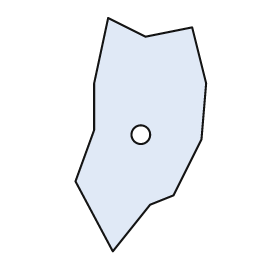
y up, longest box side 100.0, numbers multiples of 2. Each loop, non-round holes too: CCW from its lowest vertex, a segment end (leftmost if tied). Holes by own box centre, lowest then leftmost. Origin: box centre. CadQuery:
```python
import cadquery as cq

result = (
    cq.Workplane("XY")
    .moveTo(-12.0, -50.0)
    .lineTo(4.0, -30.0)
    .lineTo(14.0, -26.0)
    .lineTo(26.0, -2.0)
    .lineTo(28.0, 22.0)
    .lineTo(22.0, 46.0)
    .lineTo(2.0, 42.0)
    .lineTo(-14.0, 50.0)
    .lineTo(-20.0, 22.0)
    .lineTo(-20.0, 2.0)
    .lineTo(-28.0, -20.0)
    .close()
    .moveTo(0.0, 0.0)
    .circle(4.0)
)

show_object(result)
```